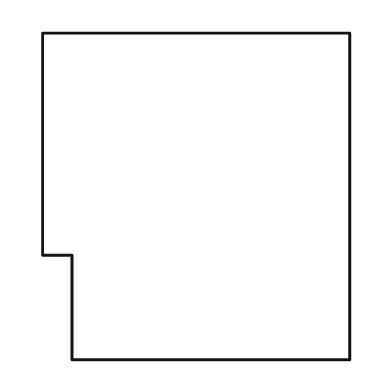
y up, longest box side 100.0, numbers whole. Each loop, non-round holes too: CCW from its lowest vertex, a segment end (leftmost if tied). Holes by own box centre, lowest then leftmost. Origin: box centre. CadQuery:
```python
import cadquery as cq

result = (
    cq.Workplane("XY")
    .moveTo(-38.0, -50.0)
    .lineTo(47.0, -50.0)
    .lineTo(47.0, 50.0)
    .lineTo(-47.0, 50.0)
    .lineTo(-47.0, -18.0)
    .lineTo(-38.0, -18.0)
    .close()
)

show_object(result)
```